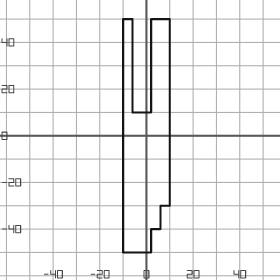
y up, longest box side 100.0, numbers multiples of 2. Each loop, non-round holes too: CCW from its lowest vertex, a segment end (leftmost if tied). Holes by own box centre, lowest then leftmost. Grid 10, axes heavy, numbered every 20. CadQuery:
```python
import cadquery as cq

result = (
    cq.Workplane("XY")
    .moveTo(-10.0, -50.0)
    .lineTo(2.0, -50.0)
    .lineTo(2.0, -40.0)
    .lineTo(6.0, -40.0)
    .lineTo(6.0, -30.0)
    .lineTo(10.0, -30.0)
    .lineTo(10.0, 50.0)
    .lineTo(2.0, 50.0)
    .lineTo(2.0, 10.0)
    .lineTo(-6.0, 10.0)
    .lineTo(-6.0, 50.0)
    .lineTo(-10.0, 50.0)
    .close()
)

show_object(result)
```